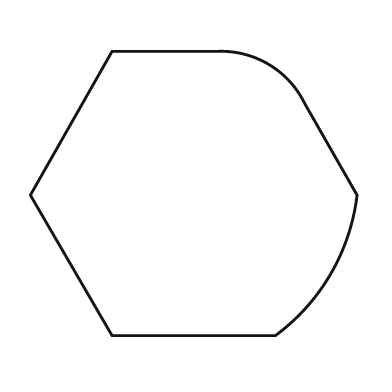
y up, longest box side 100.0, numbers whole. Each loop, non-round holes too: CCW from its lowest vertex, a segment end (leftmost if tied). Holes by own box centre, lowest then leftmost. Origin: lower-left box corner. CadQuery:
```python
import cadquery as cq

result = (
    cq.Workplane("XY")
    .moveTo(25.0, 0.0)
    .lineTo(75.0, 0.0)
    .threePointArc((92.0, 19.0), (100.0, 43.0))
    .lineTo(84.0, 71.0)
    .threePointArc((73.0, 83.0), (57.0, 87.0))
    .lineTo(25.0, 87.0)
    .lineTo(0.0, 43.0)
    .close()
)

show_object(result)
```